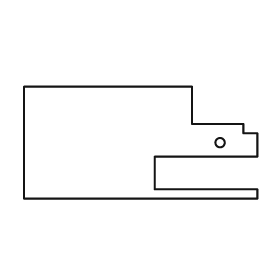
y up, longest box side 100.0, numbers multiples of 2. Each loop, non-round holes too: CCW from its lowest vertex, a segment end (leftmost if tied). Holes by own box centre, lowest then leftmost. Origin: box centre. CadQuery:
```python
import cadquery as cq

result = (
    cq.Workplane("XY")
    .moveTo(-50.0, -24.0)
    .lineTo(50.0, -24.0)
    .lineTo(50.0, -20.0)
    .lineTo(6.0, -20.0)
    .lineTo(6.0, -6.0)
    .lineTo(50.0, -6.0)
    .lineTo(50.0, 4.0)
    .lineTo(44.0, 4.0)
    .lineTo(44.0, 8.0)
    .lineTo(22.0, 8.0)
    .lineTo(22.0, 24.0)
    .lineTo(-50.0, 24.0)
    .close()
    .moveTo(34.0, 0.0)
    .circle(2.0)
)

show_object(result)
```